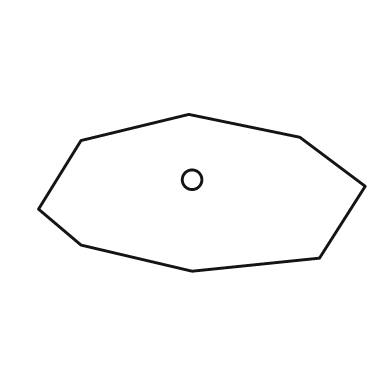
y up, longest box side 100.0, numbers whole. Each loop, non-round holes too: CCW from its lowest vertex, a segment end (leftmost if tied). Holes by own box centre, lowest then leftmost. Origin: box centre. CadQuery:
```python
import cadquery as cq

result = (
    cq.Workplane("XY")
    .moveTo(-3.0, -24.0)
    .lineTo(36.0, -20.0)
    .lineTo(50.0, 2.0)
    .lineTo(30.0, 17.0)
    .lineTo(-4.0, 24.0)
    .lineTo(-37.0, 16.0)
    .lineTo(-50.0, -5.0)
    .lineTo(-37.0, -16.0)
    .close()
    .moveTo(-3.0, 4.0)
    .circle(3.0)
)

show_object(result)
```